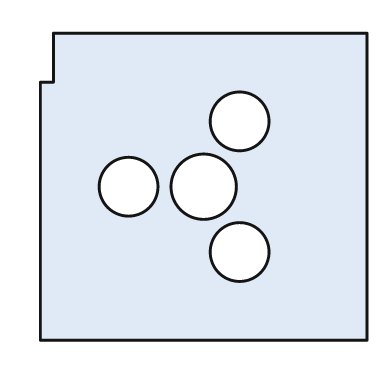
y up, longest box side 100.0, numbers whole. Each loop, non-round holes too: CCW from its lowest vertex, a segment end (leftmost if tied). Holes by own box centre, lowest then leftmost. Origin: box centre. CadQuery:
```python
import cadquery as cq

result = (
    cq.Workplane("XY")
    .moveTo(-50.0, -47.0)
    .lineTo(50.0, -47.0)
    .lineTo(50.0, 47.0)
    .lineTo(-46.0, 47.0)
    .lineTo(-46.0, 32.0)
    .lineTo(-50.0, 32.0)
    .close()
    .moveTo(11.0, -20.0)
    .circle(9.0)
    .moveTo(-23.0, 0.0)
    .circle(9.0)
    .moveTo(0.0, 0.0)
    .circle(10.0)
    .moveTo(11.0, 20.0)
    .circle(9.0)
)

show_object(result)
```